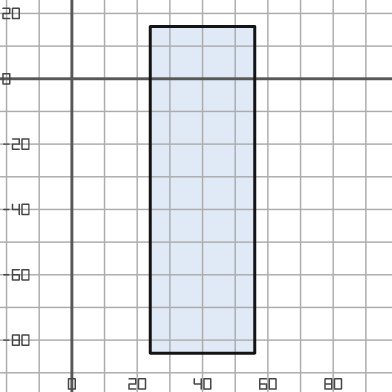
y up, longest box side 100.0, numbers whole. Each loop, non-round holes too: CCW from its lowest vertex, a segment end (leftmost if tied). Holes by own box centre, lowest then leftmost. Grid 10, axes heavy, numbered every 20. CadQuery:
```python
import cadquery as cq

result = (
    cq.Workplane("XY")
    .moveTo(24.0, -84.0)
    .lineTo(56.0, -84.0)
    .lineTo(56.0, 16.0)
    .lineTo(24.0, 16.0)
    .close()
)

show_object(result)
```